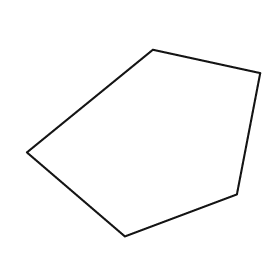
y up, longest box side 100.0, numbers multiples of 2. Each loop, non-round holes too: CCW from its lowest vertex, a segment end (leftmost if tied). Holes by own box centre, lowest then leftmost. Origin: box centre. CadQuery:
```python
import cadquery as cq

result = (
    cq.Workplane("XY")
    .moveTo(-8.0, -40.0)
    .lineTo(40.0, -22.0)
    .lineTo(50.0, 30.0)
    .lineTo(4.0, 40.0)
    .lineTo(-50.0, -4.0)
    .close()
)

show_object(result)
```